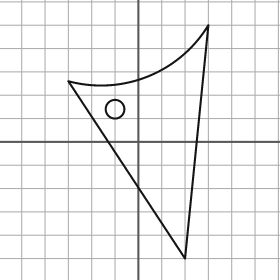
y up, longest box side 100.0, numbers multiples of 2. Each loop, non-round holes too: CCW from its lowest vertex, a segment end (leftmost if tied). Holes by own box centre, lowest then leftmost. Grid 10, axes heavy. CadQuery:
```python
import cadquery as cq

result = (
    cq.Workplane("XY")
    .moveTo(20.0, -50.0)
    .lineTo(30.0, 50.0)
    .threePointArc((4.0, 28.0), (-30.0, 26.0))
    .close()
    .moveTo(-10.0, 14.0)
    .circle(4.0)
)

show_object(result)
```